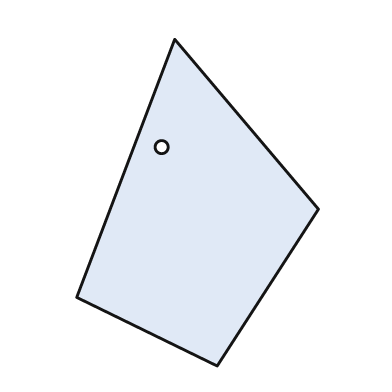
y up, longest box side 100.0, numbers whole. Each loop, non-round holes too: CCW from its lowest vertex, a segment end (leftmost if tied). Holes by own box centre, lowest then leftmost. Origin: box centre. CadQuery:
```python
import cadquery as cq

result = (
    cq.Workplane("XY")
    .moveTo(6.0, -50.0)
    .lineTo(37.0, -2.0)
    .lineTo(-7.0, 50.0)
    .lineTo(-37.0, -29.0)
    .close()
    .moveTo(-11.0, 17.0)
    .circle(2.0)
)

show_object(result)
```